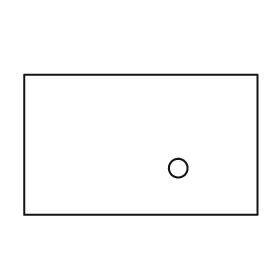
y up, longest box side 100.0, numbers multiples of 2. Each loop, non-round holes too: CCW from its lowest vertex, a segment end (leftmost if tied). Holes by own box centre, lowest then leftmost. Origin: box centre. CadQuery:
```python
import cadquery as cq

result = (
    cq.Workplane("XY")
    .moveTo(-50.0, -30.0)
    .lineTo(50.0, -30.0)
    .lineTo(50.0, 30.0)
    .lineTo(-50.0, 30.0)
    .close()
    .moveTo(16.0, -10.0)
    .circle(4.0)
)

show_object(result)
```